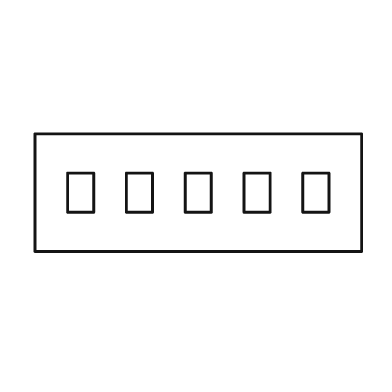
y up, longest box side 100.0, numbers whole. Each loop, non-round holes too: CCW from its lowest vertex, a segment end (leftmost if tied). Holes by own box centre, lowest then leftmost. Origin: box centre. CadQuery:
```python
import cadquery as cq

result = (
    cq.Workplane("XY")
    .moveTo(-50.0, -18.0)
    .lineTo(50.0, -18.0)
    .lineTo(50.0, 18.0)
    .lineTo(-50.0, 18.0)
    .close()
    .moveTo(-40.0, -6.0)
    .lineTo(-32.0, -6.0)
    .lineTo(-32.0, 6.0)
    .lineTo(-40.0, 6.0)
    .close()
    .moveTo(-22.0, -6.0)
    .lineTo(-14.0, -6.0)
    .lineTo(-14.0, 6.0)
    .lineTo(-22.0, 6.0)
    .close()
    .moveTo(-4.0, -6.0)
    .lineTo(4.0, -6.0)
    .lineTo(4.0, 6.0)
    .lineTo(-4.0, 6.0)
    .close()
    .moveTo(14.0, -6.0)
    .lineTo(22.0, -6.0)
    .lineTo(22.0, 6.0)
    .lineTo(14.0, 6.0)
    .close()
    .moveTo(32.0, -6.0)
    .lineTo(40.0, -6.0)
    .lineTo(40.0, 6.0)
    .lineTo(32.0, 6.0)
    .close()
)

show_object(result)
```